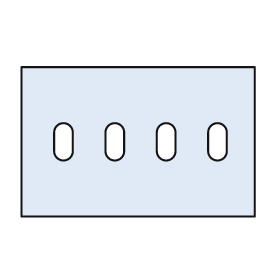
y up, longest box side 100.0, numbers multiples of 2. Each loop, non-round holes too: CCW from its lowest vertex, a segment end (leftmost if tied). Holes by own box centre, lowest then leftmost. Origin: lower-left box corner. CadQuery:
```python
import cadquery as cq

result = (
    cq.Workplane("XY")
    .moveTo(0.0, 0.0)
    .lineTo(100.0, 0.0)
    .lineTo(100.0, 64.0)
    .lineTo(0.0, 64.0)
    .close()
    .moveTo(14.0, 28.0)
    .threePointArc((18.0, 24.0), (22.0, 28.0))
    .lineTo(22.0, 36.0)
    .threePointArc((18.0, 40.0), (14.0, 36.0))
    .close()
    .moveTo(36.0, 28.0)
    .threePointArc((40.0, 24.0), (44.0, 28.0))
    .lineTo(44.0, 36.0)
    .threePointArc((40.0, 40.0), (36.0, 36.0))
    .close()
    .moveTo(58.0, 28.0)
    .threePointArc((62.0, 24.0), (66.0, 28.0))
    .lineTo(66.0, 36.0)
    .threePointArc((62.0, 40.0), (58.0, 36.0))
    .close()
    .moveTo(80.0, 28.0)
    .threePointArc((84.0, 24.0), (88.0, 28.0))
    .lineTo(88.0, 36.0)
    .threePointArc((84.0, 40.0), (80.0, 36.0))
    .close()
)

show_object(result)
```